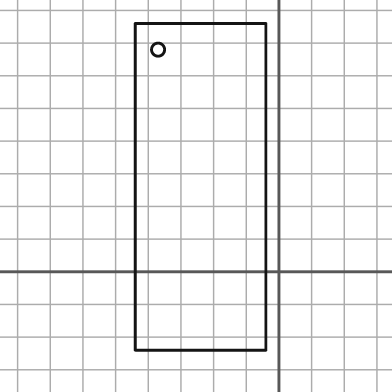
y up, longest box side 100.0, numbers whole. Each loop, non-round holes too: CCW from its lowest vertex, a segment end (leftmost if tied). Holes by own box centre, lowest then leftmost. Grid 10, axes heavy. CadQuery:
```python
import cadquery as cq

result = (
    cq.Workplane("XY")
    .moveTo(-44.0, -24.0)
    .lineTo(-4.0, -24.0)
    .lineTo(-4.0, 76.0)
    .lineTo(-44.0, 76.0)
    .close()
    .moveTo(-37.0, 68.0)
    .circle(2.0)
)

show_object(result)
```